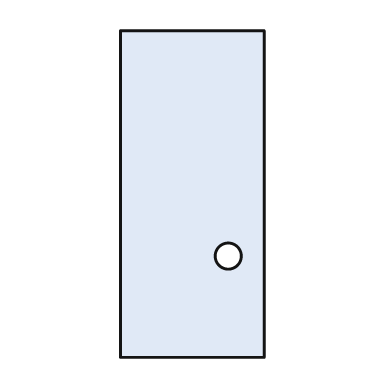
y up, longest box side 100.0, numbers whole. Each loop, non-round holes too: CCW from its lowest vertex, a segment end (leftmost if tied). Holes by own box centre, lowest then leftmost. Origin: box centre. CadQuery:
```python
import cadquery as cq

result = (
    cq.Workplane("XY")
    .moveTo(-22.0, -50.0)
    .lineTo(22.0, -50.0)
    .lineTo(22.0, 50.0)
    .lineTo(-22.0, 50.0)
    .close()
    .moveTo(11.0, -19.0)
    .circle(4.0)
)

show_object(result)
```